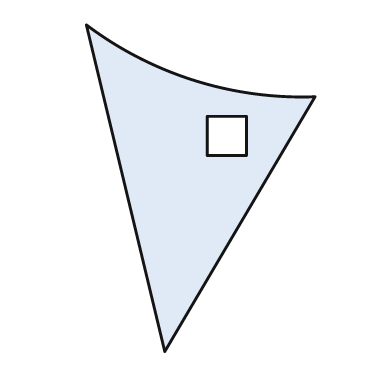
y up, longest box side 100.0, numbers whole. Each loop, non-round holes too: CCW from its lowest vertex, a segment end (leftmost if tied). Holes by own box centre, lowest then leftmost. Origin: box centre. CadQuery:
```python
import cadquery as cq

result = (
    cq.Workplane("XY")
    .moveTo(-11.0, -50.0)
    .lineTo(35.0, 28.0)
    .threePointArc((-2.0, 33.0), (-35.0, 50.0))
    .close()
    .moveTo(2.0, 10.0)
    .lineTo(14.0, 10.0)
    .lineTo(14.0, 22.0)
    .lineTo(2.0, 22.0)
    .close()
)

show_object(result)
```